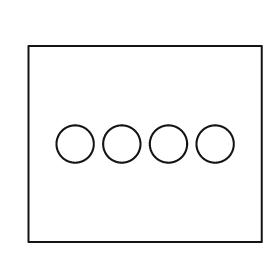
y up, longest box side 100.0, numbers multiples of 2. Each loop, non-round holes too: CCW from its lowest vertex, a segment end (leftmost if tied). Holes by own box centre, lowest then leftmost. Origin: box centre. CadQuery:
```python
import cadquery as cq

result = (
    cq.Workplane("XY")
    .moveTo(-50.0, -42.0)
    .lineTo(50.0, -42.0)
    .lineTo(50.0, 42.0)
    .lineTo(-50.0, 42.0)
    .close()
    .moveTo(-30.0, 0.0)
    .circle(8.0)
    .moveTo(-10.0, 0.0)
    .circle(8.0)
    .moveTo(10.0, 0.0)
    .circle(8.0)
    .moveTo(30.0, 0.0)
    .circle(8.0)
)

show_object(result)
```